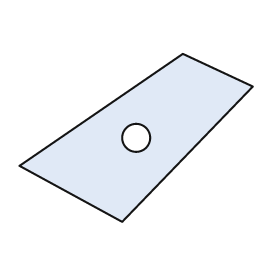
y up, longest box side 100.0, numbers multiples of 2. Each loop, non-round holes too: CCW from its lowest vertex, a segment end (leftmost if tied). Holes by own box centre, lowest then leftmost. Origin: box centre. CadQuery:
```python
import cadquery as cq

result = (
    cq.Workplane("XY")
    .moveTo(-6.0, -36.0)
    .lineTo(50.0, 22.0)
    .lineTo(20.0, 36.0)
    .lineTo(-50.0, -12.0)
    .close()
    .moveTo(0.0, 0.0)
    .circle(6.0)
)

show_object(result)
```